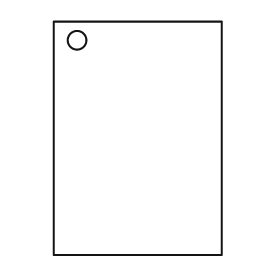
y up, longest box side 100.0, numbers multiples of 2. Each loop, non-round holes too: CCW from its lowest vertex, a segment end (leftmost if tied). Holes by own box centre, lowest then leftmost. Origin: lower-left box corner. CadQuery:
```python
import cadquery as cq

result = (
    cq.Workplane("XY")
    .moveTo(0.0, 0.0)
    .lineTo(72.0, 0.0)
    .lineTo(72.0, 100.0)
    .lineTo(0.0, 100.0)
    .close()
    .moveTo(10.0, 92.0)
    .circle(4.0)
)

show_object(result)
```